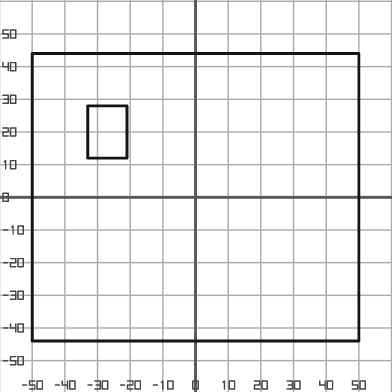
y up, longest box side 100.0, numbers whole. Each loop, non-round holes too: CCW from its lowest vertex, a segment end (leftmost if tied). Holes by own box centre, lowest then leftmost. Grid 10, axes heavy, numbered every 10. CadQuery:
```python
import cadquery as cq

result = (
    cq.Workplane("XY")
    .moveTo(-50.0, -44.0)
    .lineTo(50.0, -44.0)
    .lineTo(50.0, 44.0)
    .lineTo(-50.0, 44.0)
    .close()
    .moveTo(-33.0, 12.0)
    .lineTo(-21.0, 12.0)
    .lineTo(-21.0, 28.0)
    .lineTo(-33.0, 28.0)
    .close()
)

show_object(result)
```